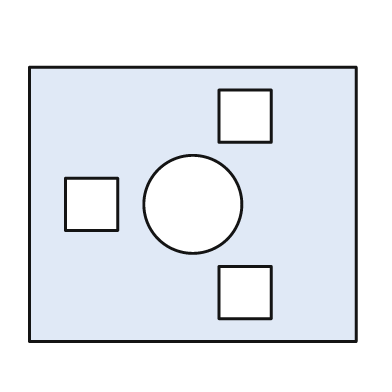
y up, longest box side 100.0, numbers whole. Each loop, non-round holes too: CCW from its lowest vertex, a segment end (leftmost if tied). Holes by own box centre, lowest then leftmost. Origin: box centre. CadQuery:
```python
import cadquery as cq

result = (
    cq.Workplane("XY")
    .moveTo(-50.0, -42.0)
    .lineTo(50.0, -42.0)
    .lineTo(50.0, 42.0)
    .lineTo(-50.0, 42.0)
    .close()
    .moveTo(8.0, -35.0)
    .lineTo(24.0, -35.0)
    .lineTo(24.0, -19.0)
    .lineTo(8.0, -19.0)
    .close()
    .moveTo(-39.0, -8.0)
    .lineTo(-23.0, -8.0)
    .lineTo(-23.0, 8.0)
    .lineTo(-39.0, 8.0)
    .close()
    .moveTo(0.0, 0.0)
    .circle(15.0)
    .moveTo(8.0, 19.0)
    .lineTo(24.0, 19.0)
    .lineTo(24.0, 35.0)
    .lineTo(8.0, 35.0)
    .close()
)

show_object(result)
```